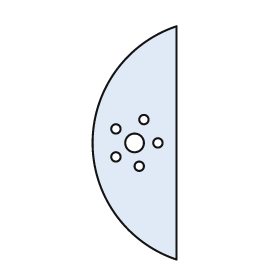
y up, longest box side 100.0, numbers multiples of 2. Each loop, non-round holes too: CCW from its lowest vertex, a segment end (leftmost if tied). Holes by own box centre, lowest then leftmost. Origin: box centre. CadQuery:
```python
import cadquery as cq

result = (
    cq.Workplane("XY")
    .moveTo(18.0, -50.0)
    .lineTo(18.0, 50.0)
    .threePointArc((-18.0, 0.0), (18.0, -50.0))
    .close()
    .moveTo(2.0, -10.0)
    .circle(2.0)
    .moveTo(-8.0, -6.0)
    .circle(2.0)
    .moveTo(0.0, 0.0)
    .circle(4.0)
    .moveTo(10.0, 0.0)
    .circle(2.0)
    .moveTo(-8.0, 6.0)
    .circle(2.0)
    .moveTo(4.0, 10.0)
    .circle(2.0)
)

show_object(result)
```